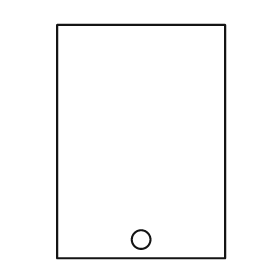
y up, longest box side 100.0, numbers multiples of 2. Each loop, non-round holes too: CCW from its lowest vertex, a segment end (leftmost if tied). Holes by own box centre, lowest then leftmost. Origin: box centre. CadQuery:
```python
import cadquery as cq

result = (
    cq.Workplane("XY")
    .moveTo(-36.0, -50.0)
    .lineTo(36.0, -50.0)
    .lineTo(36.0, 50.0)
    .lineTo(-36.0, 50.0)
    .close()
    .moveTo(0.0, -42.0)
    .circle(4.0)
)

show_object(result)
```